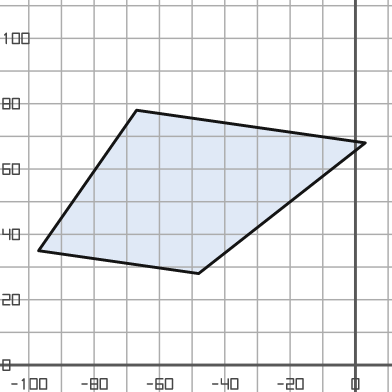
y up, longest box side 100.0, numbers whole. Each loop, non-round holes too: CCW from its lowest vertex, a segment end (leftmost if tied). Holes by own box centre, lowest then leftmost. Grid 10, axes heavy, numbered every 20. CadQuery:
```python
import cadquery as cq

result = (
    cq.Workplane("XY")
    .moveTo(-48.0, 28.0)
    .lineTo(3.0, 68.0)
    .lineTo(-67.0, 78.0)
    .lineTo(-97.0, 35.0)
    .close()
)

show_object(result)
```